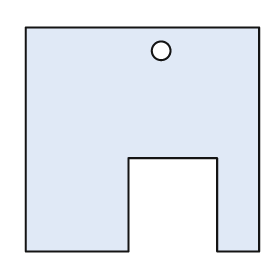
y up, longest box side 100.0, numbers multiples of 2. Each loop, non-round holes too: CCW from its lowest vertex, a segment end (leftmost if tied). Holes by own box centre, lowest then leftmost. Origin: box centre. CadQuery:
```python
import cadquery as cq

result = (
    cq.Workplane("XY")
    .moveTo(-50.0, -48.0)
    .lineTo(-6.0, -48.0)
    .lineTo(-6.0, -8.0)
    .lineTo(32.0, -8.0)
    .lineTo(32.0, -48.0)
    .lineTo(50.0, -48.0)
    .lineTo(50.0, 48.0)
    .lineTo(-50.0, 48.0)
    .close()
    .moveTo(8.0, 38.0)
    .circle(4.0)
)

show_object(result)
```